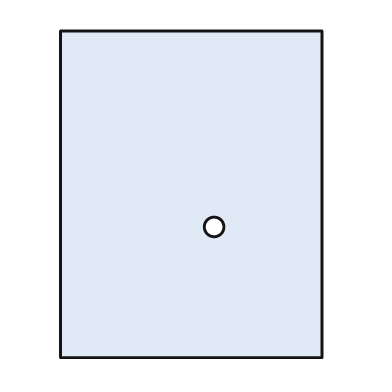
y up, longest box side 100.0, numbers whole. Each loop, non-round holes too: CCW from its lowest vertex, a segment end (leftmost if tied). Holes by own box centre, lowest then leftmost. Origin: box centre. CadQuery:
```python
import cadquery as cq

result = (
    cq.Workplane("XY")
    .moveTo(-40.0, -50.0)
    .lineTo(40.0, -50.0)
    .lineTo(40.0, 50.0)
    .lineTo(-40.0, 50.0)
    .close()
    .moveTo(7.0, -10.0)
    .circle(3.0)
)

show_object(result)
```